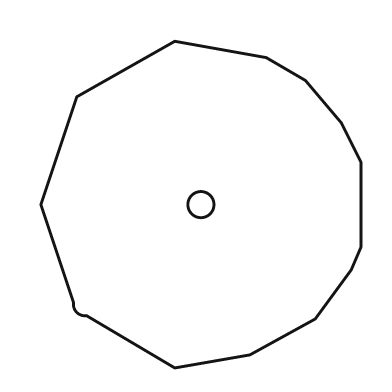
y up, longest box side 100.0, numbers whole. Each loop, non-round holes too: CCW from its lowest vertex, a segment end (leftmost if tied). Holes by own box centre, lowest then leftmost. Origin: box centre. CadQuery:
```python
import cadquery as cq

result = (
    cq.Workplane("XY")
    .moveTo(-8.0, -50.0)
    .lineTo(15.0, -46.0)
    .lineTo(35.0, -35.0)
    .lineTo(46.0, -20.0)
    .lineTo(49.0, -13.0)
    .lineTo(49.0, 13.0)
    .lineTo(43.0, 25.0)
    .lineTo(32.0, 38.0)
    .lineTo(20.0, 45.0)
    .lineTo(-8.0, 50.0)
    .lineTo(-38.0, 33.0)
    .lineTo(-49.0, 0.0)
    .lineTo(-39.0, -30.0)
    .threePointArc((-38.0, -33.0), (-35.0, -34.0))
    .close()
    .moveTo(0.0, 0.0)
    .circle(4.0)
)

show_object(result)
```